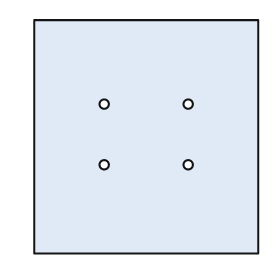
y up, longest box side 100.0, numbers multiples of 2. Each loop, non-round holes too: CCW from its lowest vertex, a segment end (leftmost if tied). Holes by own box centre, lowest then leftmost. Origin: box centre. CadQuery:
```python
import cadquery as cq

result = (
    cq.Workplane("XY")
    .moveTo(-48.0, -50.0)
    .lineTo(48.0, -50.0)
    .lineTo(48.0, 50.0)
    .lineTo(-48.0, 50.0)
    .close()
    .moveTo(-18.0, -12.0)
    .circle(2.0)
    .moveTo(18.0, -12.0)
    .circle(2.0)
    .moveTo(-18.0, 14.0)
    .circle(2.0)
    .moveTo(18.0, 14.0)
    .circle(2.0)
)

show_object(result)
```